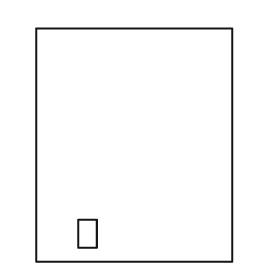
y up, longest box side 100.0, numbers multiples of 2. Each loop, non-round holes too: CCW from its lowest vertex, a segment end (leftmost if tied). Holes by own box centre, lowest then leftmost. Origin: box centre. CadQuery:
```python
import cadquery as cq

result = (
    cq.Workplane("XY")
    .moveTo(-42.0, -50.0)
    .lineTo(42.0, -50.0)
    .lineTo(42.0, 50.0)
    .lineTo(-42.0, 50.0)
    .close()
    .moveTo(-24.0, -44.0)
    .lineTo(-16.0, -44.0)
    .lineTo(-16.0, -32.0)
    .lineTo(-24.0, -32.0)
    .close()
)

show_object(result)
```